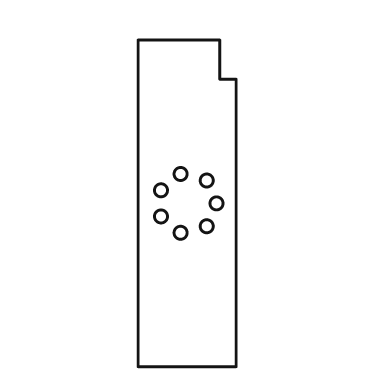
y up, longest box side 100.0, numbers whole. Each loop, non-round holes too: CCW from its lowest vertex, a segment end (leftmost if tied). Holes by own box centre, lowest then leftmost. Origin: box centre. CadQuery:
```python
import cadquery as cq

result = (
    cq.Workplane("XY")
    .moveTo(-15.0, -50.0)
    .lineTo(15.0, -50.0)
    .lineTo(15.0, 38.0)
    .lineTo(10.0, 38.0)
    .lineTo(10.0, 50.0)
    .lineTo(-15.0, 50.0)
    .close()
    .moveTo(-2.0, -9.0)
    .circle(2.0)
    .moveTo(6.0, -7.0)
    .circle(2.0)
    .moveTo(-8.0, -4.0)
    .circle(2.0)
    .moveTo(9.0, 0.0)
    .circle(2.0)
    .moveTo(-8.0, 4.0)
    .circle(2.0)
    .moveTo(6.0, 7.0)
    .circle(2.0)
    .moveTo(-2.0, 9.0)
    .circle(2.0)
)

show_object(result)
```